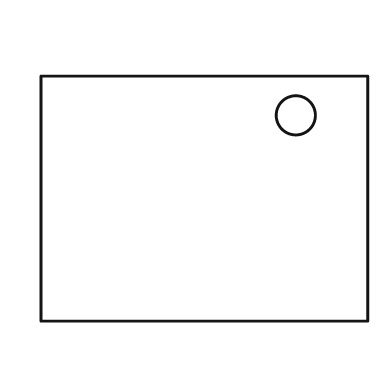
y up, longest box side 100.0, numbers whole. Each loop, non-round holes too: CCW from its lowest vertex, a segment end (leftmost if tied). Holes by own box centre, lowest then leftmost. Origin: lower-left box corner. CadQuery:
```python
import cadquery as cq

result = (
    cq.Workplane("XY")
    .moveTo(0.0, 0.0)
    .lineTo(100.0, 0.0)
    .lineTo(100.0, 75.0)
    .lineTo(0.0, 75.0)
    .close()
    .moveTo(78.0, 63.0)
    .circle(6.0)
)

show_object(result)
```